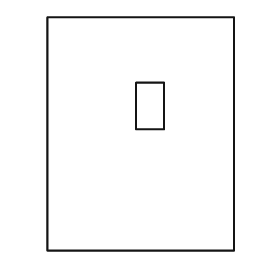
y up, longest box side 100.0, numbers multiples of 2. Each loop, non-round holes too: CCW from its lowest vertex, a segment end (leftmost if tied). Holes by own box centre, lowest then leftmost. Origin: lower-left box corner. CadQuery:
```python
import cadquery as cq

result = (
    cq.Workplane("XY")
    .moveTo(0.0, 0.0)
    .lineTo(80.0, 0.0)
    .lineTo(80.0, 100.0)
    .lineTo(0.0, 100.0)
    .close()
    .moveTo(38.0, 52.0)
    .lineTo(50.0, 52.0)
    .lineTo(50.0, 72.0)
    .lineTo(38.0, 72.0)
    .close()
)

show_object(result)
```